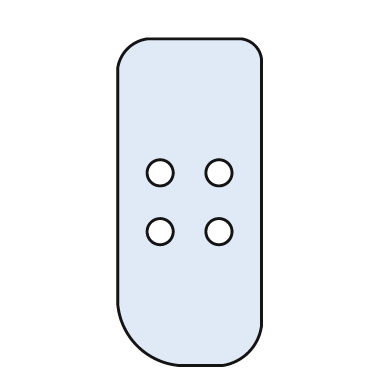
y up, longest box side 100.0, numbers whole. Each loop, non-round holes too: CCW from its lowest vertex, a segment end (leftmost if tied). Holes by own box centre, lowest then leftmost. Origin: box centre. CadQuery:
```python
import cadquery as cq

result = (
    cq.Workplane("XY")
    .moveTo(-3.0, -50.0)
    .lineTo(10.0, -50.0)
    .threePointArc((18.0, -46.0), (22.0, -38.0))
    .lineTo(22.0, 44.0)
    .threePointArc((20.0, 48.0), (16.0, 50.0))
    .lineTo(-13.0, 50.0)
    .threePointArc((-19.0, 47.0), (-22.0, 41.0))
    .lineTo(-22.0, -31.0)
    .threePointArc((-16.0, -44.0), (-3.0, -50.0))
    .close()
    .moveTo(-9.0, -9.0)
    .circle(4.0)
    .moveTo(9.0, -9.0)
    .circle(4.0)
    .moveTo(-9.0, 9.0)
    .circle(4.0)
    .moveTo(9.0, 9.0)
    .circle(4.0)
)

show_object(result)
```